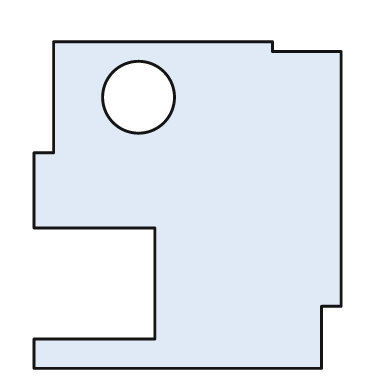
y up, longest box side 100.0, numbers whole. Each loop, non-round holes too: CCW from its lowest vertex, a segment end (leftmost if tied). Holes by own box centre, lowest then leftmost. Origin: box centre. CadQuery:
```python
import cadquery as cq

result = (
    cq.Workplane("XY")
    .moveTo(-47.0, -50.0)
    .lineTo(41.0, -50.0)
    .lineTo(41.0, -31.0)
    .lineTo(47.0, -31.0)
    .lineTo(47.0, 47.0)
    .lineTo(26.0, 47.0)
    .lineTo(26.0, 50.0)
    .lineTo(-41.0, 50.0)
    .lineTo(-41.0, 16.0)
    .lineTo(-47.0, 16.0)
    .lineTo(-47.0, -7.0)
    .lineTo(-10.0, -7.0)
    .lineTo(-10.0, -41.0)
    .lineTo(-47.0, -41.0)
    .close()
    .moveTo(-15.0, 33.0)
    .circle(11.0)
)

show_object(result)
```